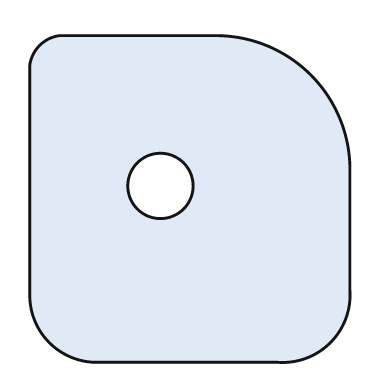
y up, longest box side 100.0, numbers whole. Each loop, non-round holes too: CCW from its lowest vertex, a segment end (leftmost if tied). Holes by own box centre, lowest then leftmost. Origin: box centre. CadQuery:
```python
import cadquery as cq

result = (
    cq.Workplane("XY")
    .moveTo(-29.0, -50.0)
    .lineTo(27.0, -50.0)
    .threePointArc((43.0, -44.0), (49.0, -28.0))
    .lineTo(49.0, 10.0)
    .threePointArc((37.0, 38.0), (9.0, 50.0))
    .lineTo(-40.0, 50.0)
    .threePointArc((-46.0, 47.0), (-49.0, 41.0))
    .lineTo(-49.0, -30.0)
    .threePointArc((-43.0, -44.0), (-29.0, -50.0))
    .close()
    .moveTo(-9.0, 4.0)
    .circle(10.0)
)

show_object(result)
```